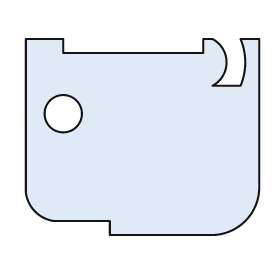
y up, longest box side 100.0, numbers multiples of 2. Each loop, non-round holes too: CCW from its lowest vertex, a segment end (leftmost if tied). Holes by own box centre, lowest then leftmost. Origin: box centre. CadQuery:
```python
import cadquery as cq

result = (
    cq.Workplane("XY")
    .moveTo(-14.0, -42.0)
    .lineTo(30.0, -42.0)
    .threePointArc((44.0, -36.0), (50.0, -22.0))
    .lineTo(50.0, 42.0)
    .lineTo(42.0, 42.0)
    .threePointArc((44.0, 32.0), (42.0, 22.0))
    .lineTo(30.0, 22.0)
    .threePointArc((36.0, 32.0), (30.0, 42.0))
    .lineTo(26.0, 42.0)
    .lineTo(26.0, 36.0)
    .lineTo(-34.0, 36.0)
    .lineTo(-34.0, 42.0)
    .lineTo(-50.0, 42.0)
    .lineTo(-50.0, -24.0)
    .threePointArc((-46.0, -32.0), (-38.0, -36.0))
    .lineTo(-14.0, -36.0)
    .close()
    .moveTo(-34.0, 10.0)
    .circle(8.0)
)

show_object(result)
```